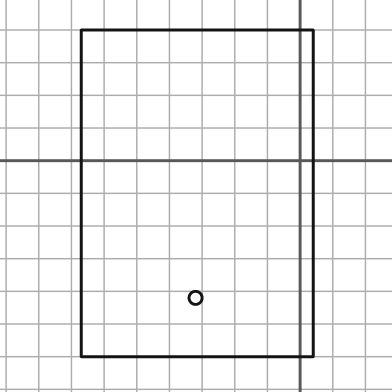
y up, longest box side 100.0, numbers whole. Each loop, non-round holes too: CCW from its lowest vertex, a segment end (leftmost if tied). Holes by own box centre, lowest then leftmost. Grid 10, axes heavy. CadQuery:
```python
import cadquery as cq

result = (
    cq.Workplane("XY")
    .moveTo(-67.0, -60.0)
    .lineTo(4.0, -60.0)
    .lineTo(4.0, 40.0)
    .lineTo(-67.0, 40.0)
    .close()
    .moveTo(-32.0, -42.0)
    .circle(2.0)
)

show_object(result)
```